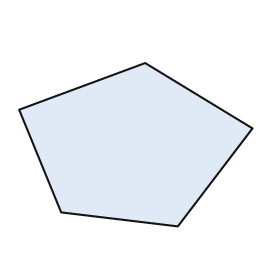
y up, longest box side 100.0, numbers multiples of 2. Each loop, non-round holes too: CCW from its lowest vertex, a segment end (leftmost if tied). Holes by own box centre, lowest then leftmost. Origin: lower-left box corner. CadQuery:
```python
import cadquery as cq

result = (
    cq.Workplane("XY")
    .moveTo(68.0, 0.0)
    .lineTo(100.0, 42.0)
    .lineTo(54.0, 70.0)
    .lineTo(0.0, 50.0)
    .lineTo(18.0, 6.0)
    .close()
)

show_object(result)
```